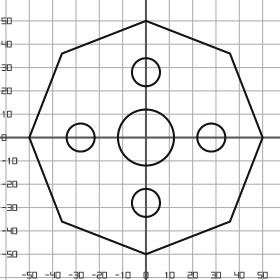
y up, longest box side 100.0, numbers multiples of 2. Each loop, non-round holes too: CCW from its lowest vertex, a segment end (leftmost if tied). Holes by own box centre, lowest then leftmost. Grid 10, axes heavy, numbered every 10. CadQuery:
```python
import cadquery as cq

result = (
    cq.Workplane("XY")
    .moveTo(0.0, -50.0)
    .lineTo(36.0, -36.0)
    .lineTo(50.0, 0.0)
    .lineTo(36.0, 36.0)
    .lineTo(0.0, 50.0)
    .lineTo(-36.0, 36.0)
    .lineTo(-50.0, 0.0)
    .lineTo(-36.0, -36.0)
    .close()
    .moveTo(0.0, -28.0)
    .circle(6.0)
    .moveTo(-28.0, 0.0)
    .circle(6.0)
    .moveTo(0.0, 0.0)
    .circle(12.0)
    .moveTo(28.0, 0.0)
    .circle(6.0)
    .moveTo(0.0, 28.0)
    .circle(6.0)
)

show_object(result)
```